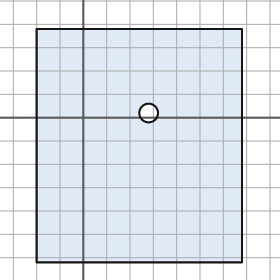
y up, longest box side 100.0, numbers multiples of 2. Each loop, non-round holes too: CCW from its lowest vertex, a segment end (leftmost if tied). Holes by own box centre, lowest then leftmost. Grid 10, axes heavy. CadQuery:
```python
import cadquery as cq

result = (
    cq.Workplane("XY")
    .moveTo(-20.0, -62.0)
    .lineTo(68.0, -62.0)
    .lineTo(68.0, 38.0)
    .lineTo(-20.0, 38.0)
    .close()
    .moveTo(28.0, 2.0)
    .circle(4.0)
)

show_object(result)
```